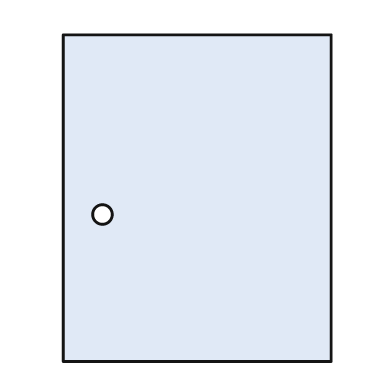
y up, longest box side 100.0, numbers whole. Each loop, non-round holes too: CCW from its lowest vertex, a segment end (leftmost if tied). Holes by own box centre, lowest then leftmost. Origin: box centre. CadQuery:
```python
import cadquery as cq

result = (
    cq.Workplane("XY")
    .moveTo(-41.0, -50.0)
    .lineTo(41.0, -50.0)
    .lineTo(41.0, 50.0)
    .lineTo(-41.0, 50.0)
    .close()
    .moveTo(-29.0, -5.0)
    .circle(3.0)
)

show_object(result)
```